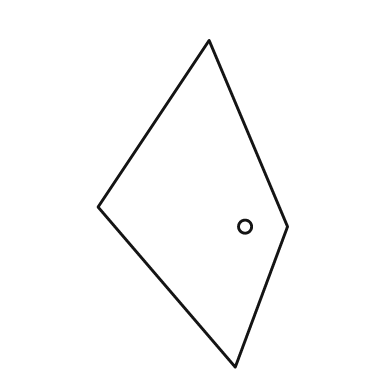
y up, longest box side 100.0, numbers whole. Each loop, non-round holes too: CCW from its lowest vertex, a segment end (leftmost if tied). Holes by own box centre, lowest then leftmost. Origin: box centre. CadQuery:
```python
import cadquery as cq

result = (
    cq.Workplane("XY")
    .moveTo(13.0, -50.0)
    .lineTo(29.0, -7.0)
    .lineTo(5.0, 50.0)
    .lineTo(-29.0, -1.0)
    .close()
    .moveTo(16.0, -7.0)
    .circle(2.0)
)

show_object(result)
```